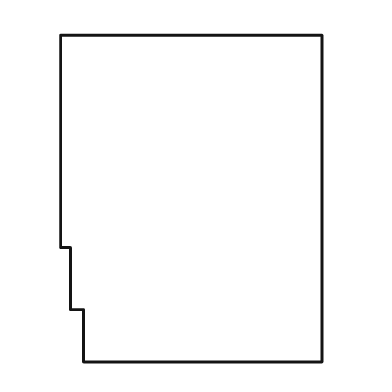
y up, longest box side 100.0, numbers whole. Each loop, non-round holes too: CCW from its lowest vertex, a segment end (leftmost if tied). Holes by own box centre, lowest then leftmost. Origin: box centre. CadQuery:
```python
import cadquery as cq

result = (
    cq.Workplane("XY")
    .moveTo(-33.0, -50.0)
    .lineTo(40.0, -50.0)
    .lineTo(40.0, 50.0)
    .lineTo(-40.0, 50.0)
    .lineTo(-40.0, -15.0)
    .lineTo(-37.0, -15.0)
    .lineTo(-37.0, -34.0)
    .lineTo(-33.0, -34.0)
    .close()
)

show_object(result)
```